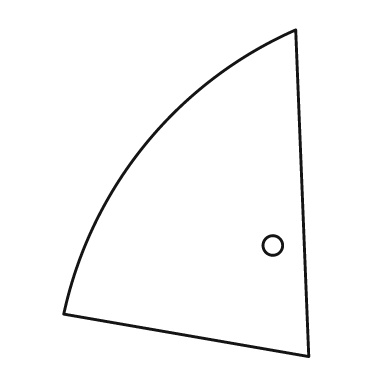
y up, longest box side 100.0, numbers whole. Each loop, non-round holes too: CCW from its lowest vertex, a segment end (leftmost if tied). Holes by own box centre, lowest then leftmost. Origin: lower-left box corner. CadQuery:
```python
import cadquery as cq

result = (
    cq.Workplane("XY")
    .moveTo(75.0, 0.0)
    .lineTo(71.0, 100.0)
    .threePointArc((25.0, 65.0), (0.0, 13.0))
    .close()
    .moveTo(64.0, 34.0)
    .circle(3.0)
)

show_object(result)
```